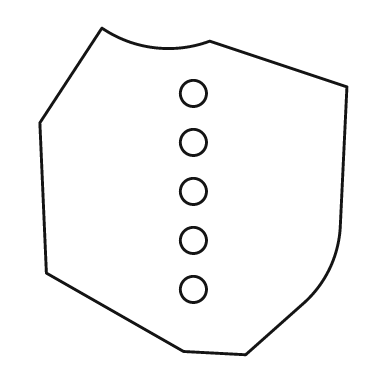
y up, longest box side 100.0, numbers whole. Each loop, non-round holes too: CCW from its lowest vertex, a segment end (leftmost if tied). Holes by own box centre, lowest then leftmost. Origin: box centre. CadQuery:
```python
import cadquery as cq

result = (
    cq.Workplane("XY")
    .moveTo(16.0, -50.0)
    .lineTo(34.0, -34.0)
    .threePointArc((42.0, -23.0), (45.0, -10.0))
    .lineTo(47.0, 32.0)
    .lineTo(5.0, 46.0)
    .threePointArc((-12.0, 44.0), (-28.0, 50.0))
    .lineTo(-47.0, 21.0)
    .lineTo(-45.0, -25.0)
    .lineTo(-3.0, -49.0)
    .close()
    .moveTo(0.0, -30.0)
    .circle(4.0)
    .moveTo(0.0, -15.0)
    .circle(4.0)
    .moveTo(0.0, 0.0)
    .circle(4.0)
    .moveTo(0.0, 15.0)
    .circle(4.0)
    .moveTo(0.0, 30.0)
    .circle(4.0)
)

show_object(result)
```